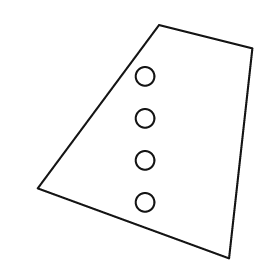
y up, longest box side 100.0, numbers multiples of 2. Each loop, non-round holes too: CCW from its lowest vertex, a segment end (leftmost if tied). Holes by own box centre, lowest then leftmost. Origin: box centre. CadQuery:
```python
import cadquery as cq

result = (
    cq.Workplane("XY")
    .moveTo(36.0, -50.0)
    .lineTo(46.0, 40.0)
    .lineTo(6.0, 50.0)
    .lineTo(-46.0, -20.0)
    .close()
    .moveTo(0.0, -26.0)
    .circle(4.0)
    .moveTo(0.0, -8.0)
    .circle(4.0)
    .moveTo(0.0, 10.0)
    .circle(4.0)
    .moveTo(0.0, 28.0)
    .circle(4.0)
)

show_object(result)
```